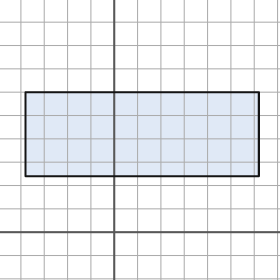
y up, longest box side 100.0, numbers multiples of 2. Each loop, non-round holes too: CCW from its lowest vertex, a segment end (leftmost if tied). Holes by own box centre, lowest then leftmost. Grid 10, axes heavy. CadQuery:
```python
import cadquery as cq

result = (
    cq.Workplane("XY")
    .moveTo(-38.0, 24.0)
    .lineTo(62.0, 24.0)
    .lineTo(62.0, 60.0)
    .lineTo(-38.0, 60.0)
    .close()
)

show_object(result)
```